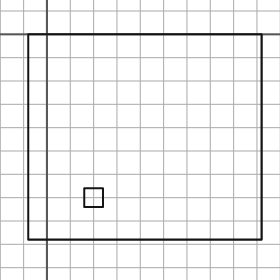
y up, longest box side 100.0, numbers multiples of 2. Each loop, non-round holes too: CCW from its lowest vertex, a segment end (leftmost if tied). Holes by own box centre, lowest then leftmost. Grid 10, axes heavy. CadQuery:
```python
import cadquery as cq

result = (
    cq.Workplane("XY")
    .moveTo(-8.0, -88.0)
    .lineTo(92.0, -88.0)
    .lineTo(92.0, 0.0)
    .lineTo(-8.0, 0.0)
    .close()
    .moveTo(16.0, -74.0)
    .lineTo(24.0, -74.0)
    .lineTo(24.0, -66.0)
    .lineTo(16.0, -66.0)
    .close()
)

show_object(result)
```